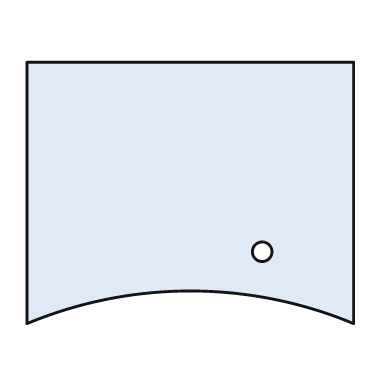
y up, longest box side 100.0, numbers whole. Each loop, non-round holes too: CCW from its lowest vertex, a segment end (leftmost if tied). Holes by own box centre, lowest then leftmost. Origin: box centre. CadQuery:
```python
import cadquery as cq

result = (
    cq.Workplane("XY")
    .moveTo(-50.0, -40.0)
    .threePointArc((0.0, -30.0), (50.0, -40.0))
    .lineTo(50.0, 40.0)
    .lineTo(-50.0, 40.0)
    .close()
    .moveTo(22.0, -18.0)
    .circle(3.0)
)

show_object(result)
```